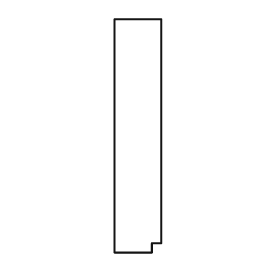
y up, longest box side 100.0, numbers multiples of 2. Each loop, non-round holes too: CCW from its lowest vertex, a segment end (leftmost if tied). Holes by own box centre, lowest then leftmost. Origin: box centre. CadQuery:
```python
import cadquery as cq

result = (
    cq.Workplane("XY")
    .moveTo(-10.0, -50.0)
    .lineTo(6.0, -50.0)
    .lineTo(6.0, -46.0)
    .lineTo(10.0, -46.0)
    .lineTo(10.0, 50.0)
    .lineTo(-10.0, 50.0)
    .close()
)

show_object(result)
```